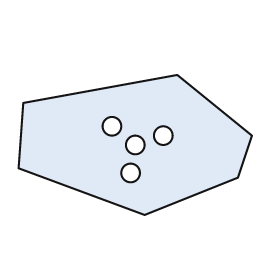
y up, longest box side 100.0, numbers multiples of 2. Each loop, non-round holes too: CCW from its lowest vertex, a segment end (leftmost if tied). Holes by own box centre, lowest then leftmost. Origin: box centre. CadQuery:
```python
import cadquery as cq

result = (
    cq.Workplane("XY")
    .moveTo(4.0, -30.0)
    .lineTo(44.0, -14.0)
    .lineTo(50.0, 4.0)
    .lineTo(18.0, 30.0)
    .lineTo(-48.0, 18.0)
    .lineTo(-50.0, -10.0)
    .close()
    .moveTo(-2.0, -12.0)
    .circle(4.0)
    .moveTo(0.0, 0.0)
    .circle(4.0)
    .moveTo(12.0, 4.0)
    .circle(4.0)
    .moveTo(-10.0, 8.0)
    .circle(4.0)
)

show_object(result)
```